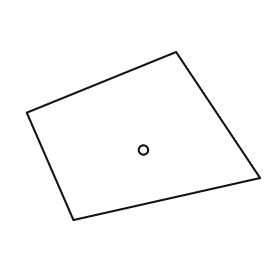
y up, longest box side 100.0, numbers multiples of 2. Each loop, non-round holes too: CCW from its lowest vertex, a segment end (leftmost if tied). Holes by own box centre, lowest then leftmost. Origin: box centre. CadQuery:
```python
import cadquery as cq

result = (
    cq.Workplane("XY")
    .moveTo(-30.0, -36.0)
    .lineTo(50.0, -18.0)
    .lineTo(14.0, 36.0)
    .lineTo(-50.0, 10.0)
    .close()
    .moveTo(0.0, -6.0)
    .circle(2.0)
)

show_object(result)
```